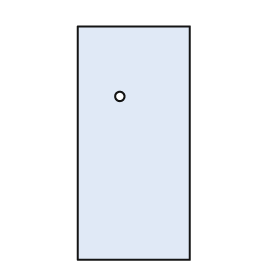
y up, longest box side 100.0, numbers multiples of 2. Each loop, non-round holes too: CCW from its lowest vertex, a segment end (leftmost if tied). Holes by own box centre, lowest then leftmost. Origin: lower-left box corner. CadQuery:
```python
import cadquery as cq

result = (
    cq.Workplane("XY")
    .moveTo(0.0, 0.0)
    .lineTo(48.0, 0.0)
    .lineTo(48.0, 100.0)
    .lineTo(0.0, 100.0)
    .close()
    .moveTo(18.0, 70.0)
    .circle(2.0)
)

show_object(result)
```